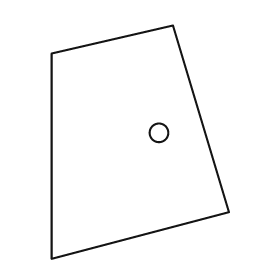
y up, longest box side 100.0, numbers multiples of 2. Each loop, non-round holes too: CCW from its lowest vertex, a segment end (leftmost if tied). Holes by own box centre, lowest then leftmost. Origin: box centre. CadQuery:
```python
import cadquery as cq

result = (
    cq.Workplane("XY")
    .moveTo(-38.0, -50.0)
    .lineTo(38.0, -30.0)
    .lineTo(14.0, 50.0)
    .lineTo(-38.0, 38.0)
    .close()
    .moveTo(8.0, 4.0)
    .circle(4.0)
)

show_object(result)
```